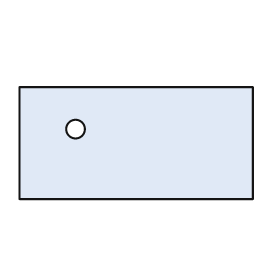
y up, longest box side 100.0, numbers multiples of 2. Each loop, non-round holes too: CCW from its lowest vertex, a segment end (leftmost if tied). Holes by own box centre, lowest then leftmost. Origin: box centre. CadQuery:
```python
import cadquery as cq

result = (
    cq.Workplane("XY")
    .moveTo(-50.0, -24.0)
    .lineTo(50.0, -24.0)
    .lineTo(50.0, 24.0)
    .lineTo(-50.0, 24.0)
    .close()
    .moveTo(-26.0, 6.0)
    .circle(4.0)
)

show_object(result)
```